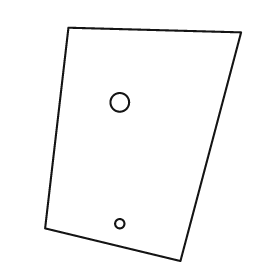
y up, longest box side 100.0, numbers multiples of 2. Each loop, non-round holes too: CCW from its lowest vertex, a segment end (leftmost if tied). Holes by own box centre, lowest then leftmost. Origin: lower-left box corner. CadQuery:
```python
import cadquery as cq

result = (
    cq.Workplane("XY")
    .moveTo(58.0, 0.0)
    .lineTo(84.0, 98.0)
    .lineTo(10.0, 100.0)
    .lineTo(0.0, 14.0)
    .close()
    .moveTo(32.0, 16.0)
    .circle(2.0)
    .moveTo(32.0, 68.0)
    .circle(4.0)
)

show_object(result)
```